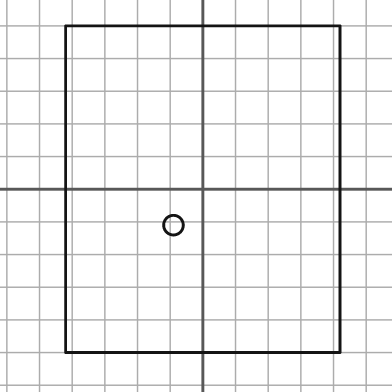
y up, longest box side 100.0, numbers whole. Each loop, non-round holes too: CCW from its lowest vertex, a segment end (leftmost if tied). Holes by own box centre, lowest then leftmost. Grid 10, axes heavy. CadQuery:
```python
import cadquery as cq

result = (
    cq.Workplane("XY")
    .moveTo(-42.0, -50.0)
    .lineTo(42.0, -50.0)
    .lineTo(42.0, 50.0)
    .lineTo(-42.0, 50.0)
    .close()
    .moveTo(-9.0, -11.0)
    .circle(3.0)
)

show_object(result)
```